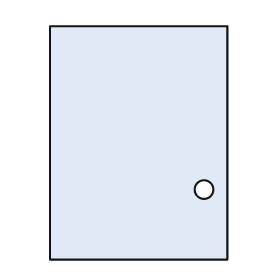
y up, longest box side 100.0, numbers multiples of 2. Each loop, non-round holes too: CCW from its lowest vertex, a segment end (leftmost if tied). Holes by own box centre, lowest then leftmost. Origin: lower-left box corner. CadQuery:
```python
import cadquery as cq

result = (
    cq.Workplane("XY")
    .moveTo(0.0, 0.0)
    .lineTo(76.0, 0.0)
    .lineTo(76.0, 100.0)
    .lineTo(0.0, 100.0)
    .close()
    .moveTo(66.0, 30.0)
    .circle(4.0)
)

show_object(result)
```